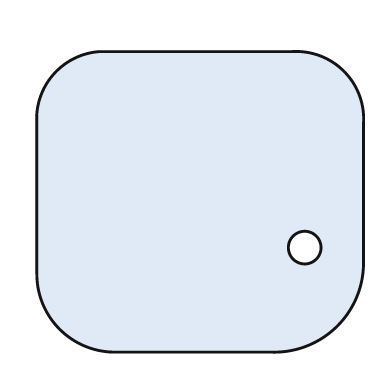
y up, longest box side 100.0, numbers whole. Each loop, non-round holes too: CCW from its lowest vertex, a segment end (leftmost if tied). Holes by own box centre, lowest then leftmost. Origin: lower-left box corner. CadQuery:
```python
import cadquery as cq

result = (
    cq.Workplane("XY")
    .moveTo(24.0, 0.0)
    .lineTo(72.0, 0.0)
    .threePointArc((92.0, 8.0), (100.0, 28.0))
    .lineTo(100.0, 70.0)
    .threePointArc((94.0, 86.0), (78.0, 92.0))
    .lineTo(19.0, 92.0)
    .threePointArc((6.0, 86.0), (0.0, 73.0))
    .lineTo(0.0, 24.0)
    .threePointArc((7.0, 7.0), (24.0, 0.0))
    .close()
    .moveTo(82.0, 32.0)
    .circle(5.0)
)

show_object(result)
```